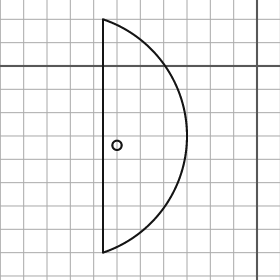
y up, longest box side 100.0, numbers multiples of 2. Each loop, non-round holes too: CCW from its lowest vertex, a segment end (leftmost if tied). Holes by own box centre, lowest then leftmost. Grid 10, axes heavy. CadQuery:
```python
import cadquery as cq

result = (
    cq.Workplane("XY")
    .moveTo(-66.0, -80.0)
    .threePointArc((-30.0, -30.0), (-66.0, 20.0))
    .close()
    .moveTo(-60.0, -34.0)
    .circle(2.0)
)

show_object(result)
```